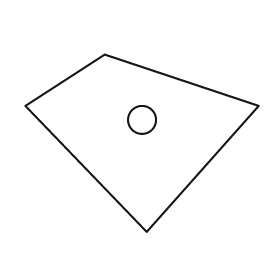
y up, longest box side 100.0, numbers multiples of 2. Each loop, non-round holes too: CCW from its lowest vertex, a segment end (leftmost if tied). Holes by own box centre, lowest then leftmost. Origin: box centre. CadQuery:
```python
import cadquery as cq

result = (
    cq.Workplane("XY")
    .moveTo(2.0, -38.0)
    .lineTo(50.0, 16.0)
    .lineTo(-16.0, 38.0)
    .lineTo(-50.0, 16.0)
    .close()
    .moveTo(0.0, 10.0)
    .circle(6.0)
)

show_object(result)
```